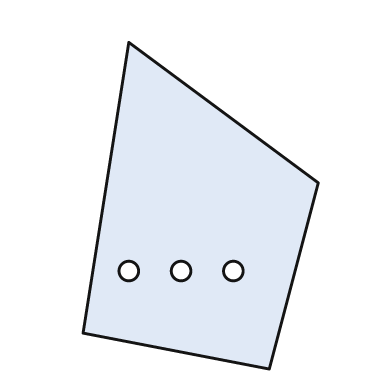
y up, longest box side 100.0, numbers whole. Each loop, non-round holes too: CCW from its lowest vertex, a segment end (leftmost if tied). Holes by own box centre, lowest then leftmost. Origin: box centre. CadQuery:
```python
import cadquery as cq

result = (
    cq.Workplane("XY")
    .moveTo(21.0, -50.0)
    .lineTo(36.0, 7.0)
    .lineTo(-22.0, 50.0)
    .lineTo(-36.0, -39.0)
    .close()
    .moveTo(-22.0, -20.0)
    .circle(3.0)
    .moveTo(-6.0, -20.0)
    .circle(3.0)
    .moveTo(10.0, -20.0)
    .circle(3.0)
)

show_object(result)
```